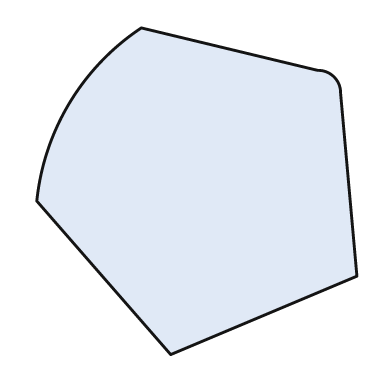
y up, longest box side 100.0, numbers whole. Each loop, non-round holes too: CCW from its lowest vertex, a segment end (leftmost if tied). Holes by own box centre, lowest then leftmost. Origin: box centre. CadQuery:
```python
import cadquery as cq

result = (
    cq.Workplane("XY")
    .moveTo(-8.0, -50.0)
    .lineTo(49.0, -26.0)
    .lineTo(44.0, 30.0)
    .threePointArc((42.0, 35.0), (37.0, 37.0))
    .lineTo(-17.0, 50.0)
    .threePointArc((-39.0, 27.0), (-49.0, -3.0))
    .close()
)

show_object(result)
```